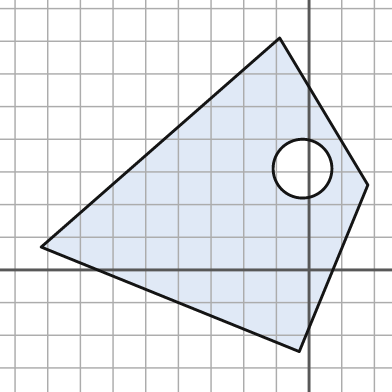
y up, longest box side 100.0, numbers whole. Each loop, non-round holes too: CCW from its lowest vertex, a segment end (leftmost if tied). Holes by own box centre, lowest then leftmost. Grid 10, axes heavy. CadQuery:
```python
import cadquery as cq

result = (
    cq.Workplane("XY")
    .moveTo(-3.0, -25.0)
    .lineTo(18.0, 26.0)
    .lineTo(-9.0, 71.0)
    .lineTo(-82.0, 7.0)
    .close()
    .moveTo(-2.0, 31.0)
    .circle(9.0)
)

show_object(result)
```